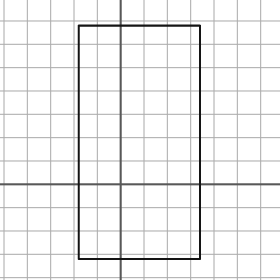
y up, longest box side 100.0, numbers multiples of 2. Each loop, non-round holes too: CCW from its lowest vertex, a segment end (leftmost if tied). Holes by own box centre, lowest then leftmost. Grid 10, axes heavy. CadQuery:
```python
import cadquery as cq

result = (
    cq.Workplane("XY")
    .moveTo(-18.0, -32.0)
    .lineTo(34.0, -32.0)
    .lineTo(34.0, 68.0)
    .lineTo(-18.0, 68.0)
    .close()
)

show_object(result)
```